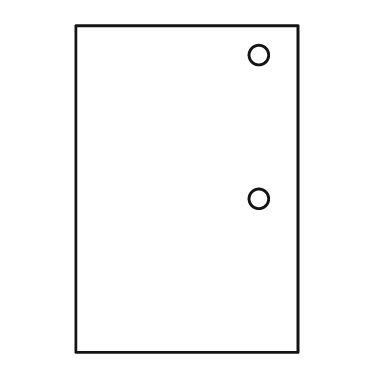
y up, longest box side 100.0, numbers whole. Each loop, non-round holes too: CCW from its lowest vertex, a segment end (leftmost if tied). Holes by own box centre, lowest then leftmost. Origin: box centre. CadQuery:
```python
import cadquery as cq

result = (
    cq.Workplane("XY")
    .moveTo(-34.0, -50.0)
    .lineTo(34.0, -50.0)
    .lineTo(34.0, 50.0)
    .lineTo(-34.0, 50.0)
    .close()
    .moveTo(22.0, -3.0)
    .circle(3.0)
    .moveTo(22.0, 41.0)
    .circle(3.0)
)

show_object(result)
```